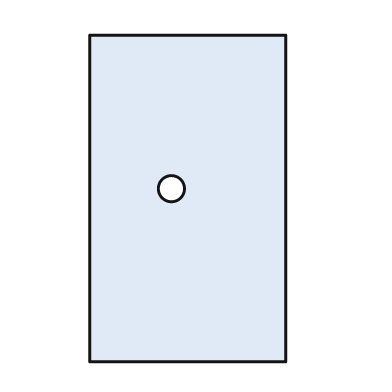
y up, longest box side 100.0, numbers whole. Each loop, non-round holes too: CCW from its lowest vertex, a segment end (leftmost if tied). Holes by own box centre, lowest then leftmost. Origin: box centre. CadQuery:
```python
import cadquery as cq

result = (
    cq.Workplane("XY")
    .moveTo(-30.0, -50.0)
    .lineTo(30.0, -50.0)
    .lineTo(30.0, 50.0)
    .lineTo(-30.0, 50.0)
    .close()
    .moveTo(-5.0, 3.0)
    .circle(4.0)
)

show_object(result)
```